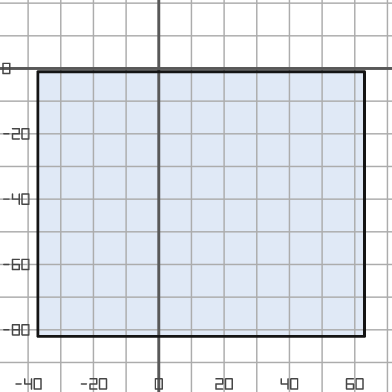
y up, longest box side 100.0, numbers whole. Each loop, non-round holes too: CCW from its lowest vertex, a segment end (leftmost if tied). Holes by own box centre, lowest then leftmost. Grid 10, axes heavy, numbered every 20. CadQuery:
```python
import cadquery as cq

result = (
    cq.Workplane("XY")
    .moveTo(-37.0, -82.0)
    .lineTo(63.0, -82.0)
    .lineTo(63.0, -1.0)
    .lineTo(-37.0, -1.0)
    .close()
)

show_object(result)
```